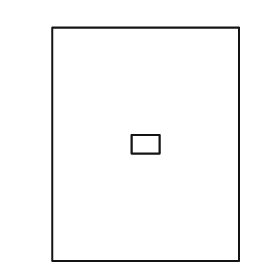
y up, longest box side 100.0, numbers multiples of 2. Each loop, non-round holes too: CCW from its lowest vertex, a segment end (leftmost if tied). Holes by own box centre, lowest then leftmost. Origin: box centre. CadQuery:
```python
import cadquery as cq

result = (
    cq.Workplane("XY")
    .moveTo(-40.0, -50.0)
    .lineTo(40.0, -50.0)
    .lineTo(40.0, 50.0)
    .lineTo(-40.0, 50.0)
    .close()
    .moveTo(-6.0, -4.0)
    .lineTo(6.0, -4.0)
    .lineTo(6.0, 4.0)
    .lineTo(-6.0, 4.0)
    .close()
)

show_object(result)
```